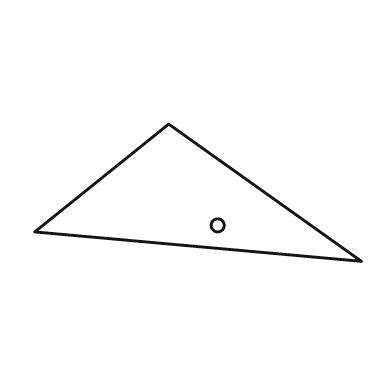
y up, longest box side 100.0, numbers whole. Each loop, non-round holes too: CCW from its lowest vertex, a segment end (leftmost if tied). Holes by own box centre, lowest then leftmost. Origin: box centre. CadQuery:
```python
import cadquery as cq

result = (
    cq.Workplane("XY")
    .moveTo(50.0, -21.0)
    .lineTo(-9.0, 21.0)
    .lineTo(-50.0, -12.0)
    .close()
    .moveTo(6.0, -10.0)
    .circle(2.0)
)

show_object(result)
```